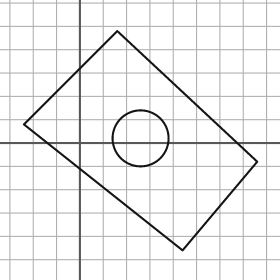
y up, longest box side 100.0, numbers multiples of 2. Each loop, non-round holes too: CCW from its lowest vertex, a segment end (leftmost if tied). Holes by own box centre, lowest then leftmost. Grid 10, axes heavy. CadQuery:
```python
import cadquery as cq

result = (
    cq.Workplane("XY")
    .moveTo(44.0, -46.0)
    .lineTo(76.0, -8.0)
    .lineTo(16.0, 48.0)
    .lineTo(-24.0, 8.0)
    .close()
    .moveTo(26.0, 2.0)
    .circle(12.0)
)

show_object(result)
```